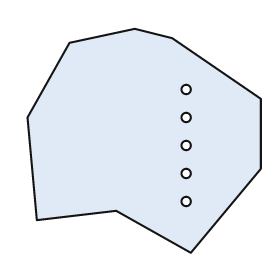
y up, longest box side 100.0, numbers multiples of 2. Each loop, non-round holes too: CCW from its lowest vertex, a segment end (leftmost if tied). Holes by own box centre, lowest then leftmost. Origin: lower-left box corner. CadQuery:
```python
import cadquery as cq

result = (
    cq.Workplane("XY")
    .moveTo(70.0, 0.0)
    .lineTo(100.0, 36.0)
    .lineTo(100.0, 66.0)
    .lineTo(62.0, 92.0)
    .lineTo(46.0, 96.0)
    .lineTo(18.0, 90.0)
    .lineTo(0.0, 58.0)
    .lineTo(4.0, 14.0)
    .lineTo(38.0, 18.0)
    .close()
    .moveTo(68.0, 22.0)
    .circle(2.0)
    .moveTo(68.0, 34.0)
    .circle(2.0)
    .moveTo(68.0, 46.0)
    .circle(2.0)
    .moveTo(68.0, 58.0)
    .circle(2.0)
    .moveTo(68.0, 70.0)
    .circle(2.0)
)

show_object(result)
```